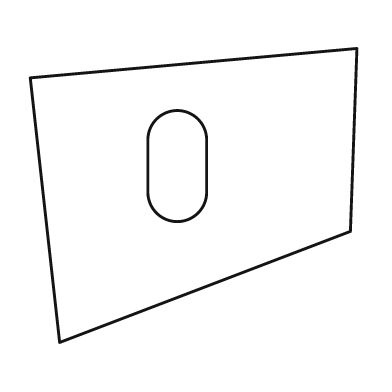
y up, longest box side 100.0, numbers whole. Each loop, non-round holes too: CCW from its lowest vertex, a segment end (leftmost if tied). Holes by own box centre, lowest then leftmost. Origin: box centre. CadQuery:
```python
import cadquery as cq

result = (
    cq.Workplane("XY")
    .moveTo(-41.0, -45.0)
    .lineTo(48.0, -11.0)
    .lineTo(50.0, 45.0)
    .lineTo(-50.0, 36.0)
    .close()
    .moveTo(-14.0, 1.0)
    .threePointArc((-5.0, -8.0), (4.0, 1.0))
    .lineTo(4.0, 17.0)
    .threePointArc((-5.0, 26.0), (-14.0, 17.0))
    .close()
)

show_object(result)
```